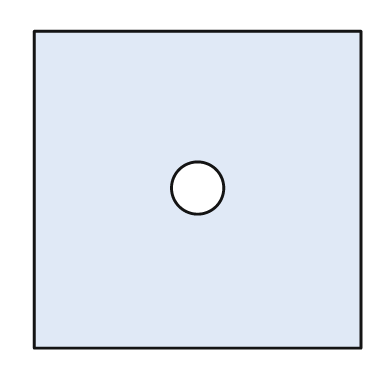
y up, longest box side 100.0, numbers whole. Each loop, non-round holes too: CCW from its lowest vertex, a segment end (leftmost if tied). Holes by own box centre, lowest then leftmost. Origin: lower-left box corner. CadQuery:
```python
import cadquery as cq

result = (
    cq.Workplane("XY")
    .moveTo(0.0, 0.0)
    .lineTo(100.0, 0.0)
    .lineTo(100.0, 97.0)
    .lineTo(0.0, 97.0)
    .close()
    .moveTo(50.0, 49.0)
    .circle(8.0)
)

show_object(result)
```